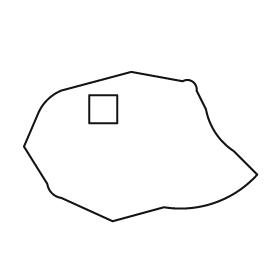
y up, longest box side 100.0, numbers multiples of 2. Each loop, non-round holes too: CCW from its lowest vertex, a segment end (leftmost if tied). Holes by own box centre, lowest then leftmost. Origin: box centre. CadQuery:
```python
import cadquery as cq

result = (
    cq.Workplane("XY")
    .moveTo(-12.0, -32.0)
    .lineTo(10.0, -26.0)
    .threePointArc((32.0, -24.0), (50.0, -12.0))
    .lineTo(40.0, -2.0)
    .threePointArc((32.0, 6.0), (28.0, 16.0))
    .lineTo(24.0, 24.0)
    .threePointArc((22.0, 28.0), (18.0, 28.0))
    .lineTo(-4.0, 32.0)
    .lineTo(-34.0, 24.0)
    .threePointArc((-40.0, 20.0), (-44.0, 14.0))
    .lineTo(-50.0, 0.0)
    .lineTo(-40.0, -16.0)
    .threePointArc((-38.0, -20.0), (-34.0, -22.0))
    .close()
    .moveTo(-22.0, 10.0)
    .lineTo(-10.0, 10.0)
    .lineTo(-10.0, 22.0)
    .lineTo(-22.0, 22.0)
    .close()
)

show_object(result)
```